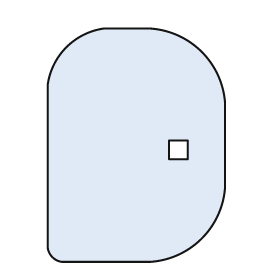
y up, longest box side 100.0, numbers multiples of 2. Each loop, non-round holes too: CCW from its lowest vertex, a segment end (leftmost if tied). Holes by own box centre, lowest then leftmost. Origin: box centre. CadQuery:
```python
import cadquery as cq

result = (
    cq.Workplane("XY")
    .moveTo(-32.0, -50.0)
    .lineTo(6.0, -50.0)
    .threePointArc((28.0, -40.0), (38.0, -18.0))
    .lineTo(38.0, 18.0)
    .threePointArc((28.0, 40.0), (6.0, 50.0))
    .lineTo(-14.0, 50.0)
    .threePointArc((-30.0, 42.0), (-38.0, 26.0))
    .lineTo(-38.0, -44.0)
    .threePointArc((-36.0, -48.0), (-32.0, -50.0))
    .close()
    .moveTo(14.0, -6.0)
    .lineTo(22.0, -6.0)
    .lineTo(22.0, 2.0)
    .lineTo(14.0, 2.0)
    .close()
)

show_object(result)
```